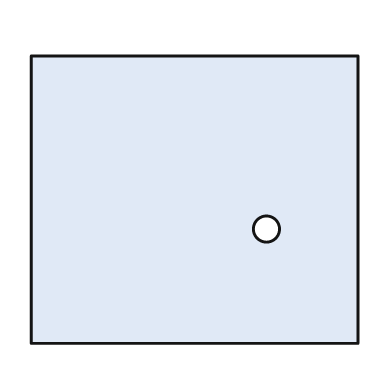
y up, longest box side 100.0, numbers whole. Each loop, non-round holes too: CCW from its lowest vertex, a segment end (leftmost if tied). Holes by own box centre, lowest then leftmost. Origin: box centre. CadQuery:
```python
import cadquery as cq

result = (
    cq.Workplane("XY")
    .moveTo(-50.0, -44.0)
    .lineTo(50.0, -44.0)
    .lineTo(50.0, 44.0)
    .lineTo(-50.0, 44.0)
    .close()
    .moveTo(22.0, -9.0)
    .circle(4.0)
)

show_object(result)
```